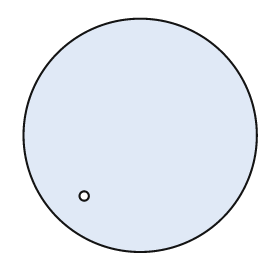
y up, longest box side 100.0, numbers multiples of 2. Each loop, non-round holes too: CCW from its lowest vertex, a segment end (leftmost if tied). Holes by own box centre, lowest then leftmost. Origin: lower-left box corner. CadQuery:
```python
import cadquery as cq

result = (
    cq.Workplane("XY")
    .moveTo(50.0, 50.0)
    .circle(50.0)
    .moveTo(26.0, 24.0)
    .circle(2.0)
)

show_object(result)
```